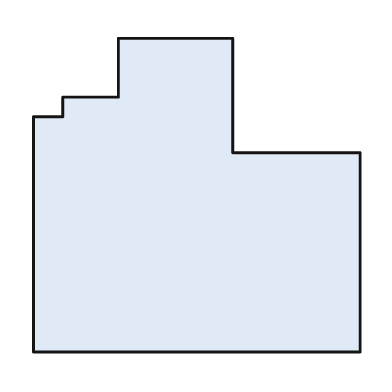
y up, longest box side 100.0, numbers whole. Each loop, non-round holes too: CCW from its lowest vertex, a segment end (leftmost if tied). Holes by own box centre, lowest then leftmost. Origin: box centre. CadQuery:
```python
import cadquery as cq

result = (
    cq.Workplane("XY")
    .moveTo(-50.0, -48.0)
    .lineTo(50.0, -48.0)
    .lineTo(50.0, 13.0)
    .lineTo(11.0, 13.0)
    .lineTo(11.0, 48.0)
    .lineTo(-24.0, 48.0)
    .lineTo(-24.0, 30.0)
    .lineTo(-41.0, 30.0)
    .lineTo(-41.0, 24.0)
    .lineTo(-50.0, 24.0)
    .close()
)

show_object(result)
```